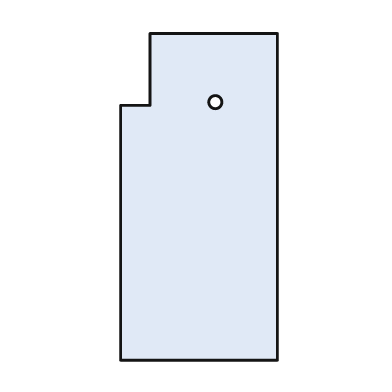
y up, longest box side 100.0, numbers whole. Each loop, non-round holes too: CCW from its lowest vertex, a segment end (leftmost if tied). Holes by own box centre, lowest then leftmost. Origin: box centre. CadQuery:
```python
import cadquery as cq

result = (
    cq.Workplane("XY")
    .moveTo(-24.0, -50.0)
    .lineTo(24.0, -50.0)
    .lineTo(24.0, 50.0)
    .lineTo(-15.0, 50.0)
    .lineTo(-15.0, 28.0)
    .lineTo(-24.0, 28.0)
    .close()
    .moveTo(5.0, 29.0)
    .circle(2.0)
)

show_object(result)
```